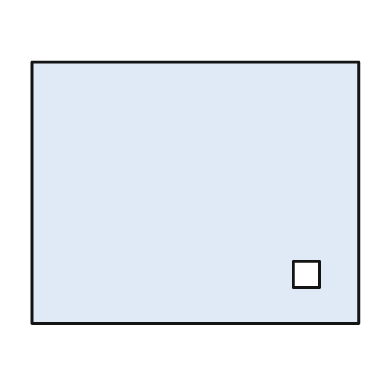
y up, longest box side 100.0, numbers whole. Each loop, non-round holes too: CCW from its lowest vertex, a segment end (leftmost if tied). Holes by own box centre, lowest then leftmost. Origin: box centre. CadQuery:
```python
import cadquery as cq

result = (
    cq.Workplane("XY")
    .moveTo(-50.0, -40.0)
    .lineTo(50.0, -40.0)
    .lineTo(50.0, 40.0)
    .lineTo(-50.0, 40.0)
    .close()
    .moveTo(30.0, -29.0)
    .lineTo(38.0, -29.0)
    .lineTo(38.0, -21.0)
    .lineTo(30.0, -21.0)
    .close()
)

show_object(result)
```